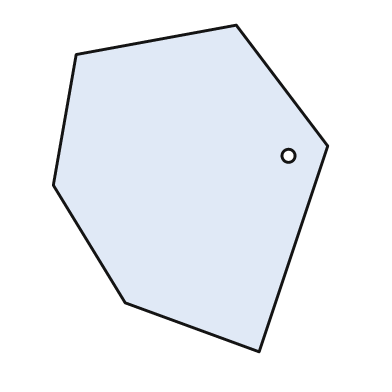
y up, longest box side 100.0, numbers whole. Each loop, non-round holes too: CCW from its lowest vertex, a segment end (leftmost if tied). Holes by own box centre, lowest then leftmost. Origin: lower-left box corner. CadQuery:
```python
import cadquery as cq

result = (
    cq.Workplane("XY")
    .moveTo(63.0, 0.0)
    .lineTo(84.0, 63.0)
    .lineTo(56.0, 100.0)
    .lineTo(7.0, 91.0)
    .lineTo(0.0, 51.0)
    .lineTo(22.0, 15.0)
    .close()
    .moveTo(72.0, 60.0)
    .circle(2.0)
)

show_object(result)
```